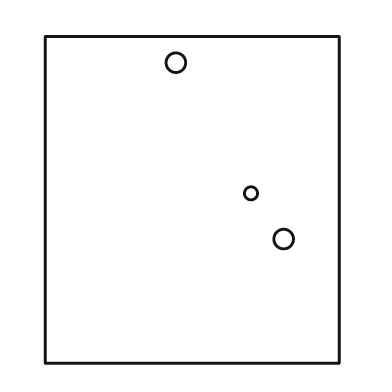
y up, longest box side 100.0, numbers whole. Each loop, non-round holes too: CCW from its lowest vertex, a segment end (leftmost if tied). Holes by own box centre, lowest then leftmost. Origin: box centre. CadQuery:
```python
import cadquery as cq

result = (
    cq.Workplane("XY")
    .moveTo(-45.0, -50.0)
    .lineTo(45.0, -50.0)
    .lineTo(45.0, 50.0)
    .lineTo(-45.0, 50.0)
    .close()
    .moveTo(28.0, -12.0)
    .circle(3.0)
    .moveTo(18.0, 2.0)
    .circle(2.0)
    .moveTo(-5.0, 42.0)
    .circle(3.0)
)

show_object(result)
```